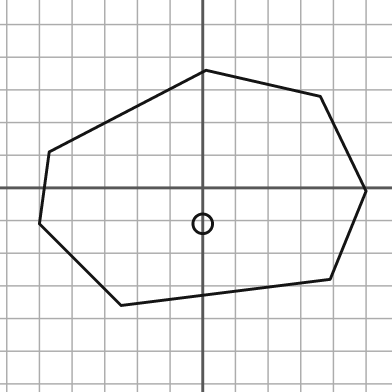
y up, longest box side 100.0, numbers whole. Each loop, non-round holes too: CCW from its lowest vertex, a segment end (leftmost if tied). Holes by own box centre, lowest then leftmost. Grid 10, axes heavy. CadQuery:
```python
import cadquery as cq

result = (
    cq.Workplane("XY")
    .moveTo(-25.0, -36.0)
    .lineTo(39.0, -28.0)
    .lineTo(50.0, -1.0)
    .lineTo(36.0, 28.0)
    .lineTo(1.0, 36.0)
    .lineTo(-47.0, 11.0)
    .lineTo(-50.0, -11.0)
    .close()
    .moveTo(0.0, -11.0)
    .circle(3.0)
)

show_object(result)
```